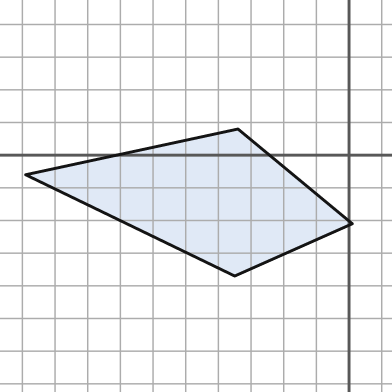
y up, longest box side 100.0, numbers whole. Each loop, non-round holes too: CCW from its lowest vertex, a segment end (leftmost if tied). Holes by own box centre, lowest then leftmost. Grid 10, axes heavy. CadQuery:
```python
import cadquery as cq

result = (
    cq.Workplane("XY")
    .moveTo(-35.0, -37.0)
    .lineTo(1.0, -21.0)
    .lineTo(-34.0, 8.0)
    .lineTo(-99.0, -6.0)
    .close()
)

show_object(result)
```